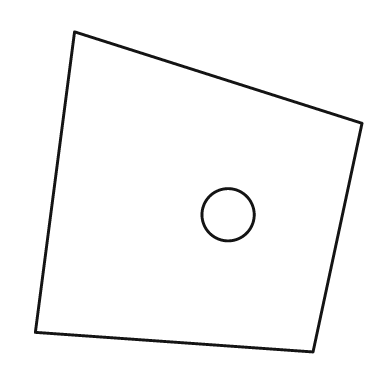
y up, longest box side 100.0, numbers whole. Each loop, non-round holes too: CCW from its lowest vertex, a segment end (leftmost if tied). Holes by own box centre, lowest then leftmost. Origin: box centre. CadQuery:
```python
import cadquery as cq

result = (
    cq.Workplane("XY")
    .moveTo(35.0, -49.0)
    .lineTo(50.0, 21.0)
    .lineTo(-38.0, 49.0)
    .lineTo(-50.0, -43.0)
    .close()
    .moveTo(9.0, -7.0)
    .circle(8.0)
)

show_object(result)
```